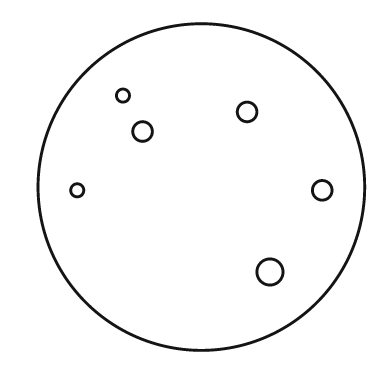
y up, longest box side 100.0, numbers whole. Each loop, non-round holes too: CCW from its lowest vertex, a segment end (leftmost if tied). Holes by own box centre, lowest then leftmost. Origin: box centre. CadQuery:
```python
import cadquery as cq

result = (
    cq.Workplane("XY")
    .moveTo(0.0, 0.0)
    .circle(50.0)
    .moveTo(21.0, -26.0)
    .circle(4.0)
    .moveTo(-38.0, -1.0)
    .circle(2.0)
    .moveTo(37.0, -1.0)
    .circle(3.0)
    .moveTo(-18.0, 17.0)
    .circle(3.0)
    .moveTo(14.0, 23.0)
    .circle(3.0)
    .moveTo(-24.0, 28.0)
    .circle(2.0)
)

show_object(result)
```